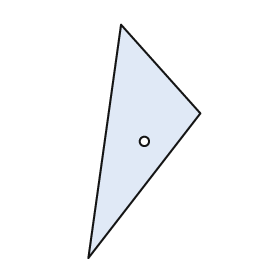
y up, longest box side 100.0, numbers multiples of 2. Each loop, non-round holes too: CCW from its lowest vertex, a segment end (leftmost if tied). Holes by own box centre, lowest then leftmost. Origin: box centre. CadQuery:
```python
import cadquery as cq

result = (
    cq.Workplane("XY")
    .moveTo(-24.0, -50.0)
    .lineTo(24.0, 12.0)
    .lineTo(-10.0, 50.0)
    .close()
    .moveTo(0.0, 0.0)
    .circle(2.0)
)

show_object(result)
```